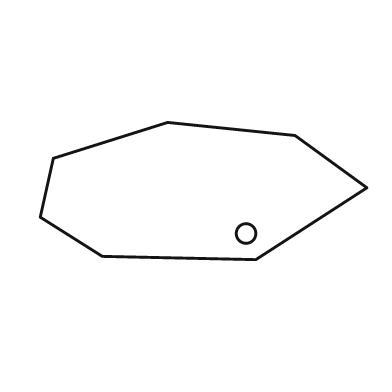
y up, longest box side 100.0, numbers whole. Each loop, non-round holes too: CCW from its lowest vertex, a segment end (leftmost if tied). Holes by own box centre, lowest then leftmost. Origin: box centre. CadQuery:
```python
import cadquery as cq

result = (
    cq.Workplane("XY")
    .moveTo(16.0, -21.0)
    .lineTo(50.0, 1.0)
    .lineTo(28.0, 17.0)
    .lineTo(-11.0, 21.0)
    .lineTo(-46.0, 10.0)
    .lineTo(-50.0, -8.0)
    .lineTo(-31.0, -20.0)
    .close()
    .moveTo(13.0, -13.0)
    .circle(3.0)
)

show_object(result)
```